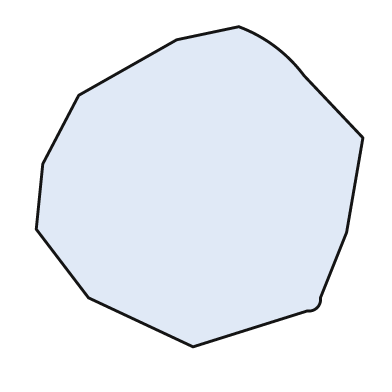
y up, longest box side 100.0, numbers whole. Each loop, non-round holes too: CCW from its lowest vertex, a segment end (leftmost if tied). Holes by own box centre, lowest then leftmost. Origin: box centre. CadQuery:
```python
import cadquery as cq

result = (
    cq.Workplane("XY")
    .moveTo(-2.0, -49.0)
    .lineTo(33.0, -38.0)
    .threePointArc((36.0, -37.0), (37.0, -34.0))
    .lineTo(45.0, -14.0)
    .lineTo(50.0, 15.0)
    .lineTo(32.0, 34.0)
    .threePointArc((23.0, 43.0), (12.0, 49.0))
    .lineTo(-7.0, 45.0)
    .lineTo(-37.0, 28.0)
    .lineTo(-48.0, 7.0)
    .lineTo(-50.0, -13.0)
    .lineTo(-34.0, -34.0)
    .close()
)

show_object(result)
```